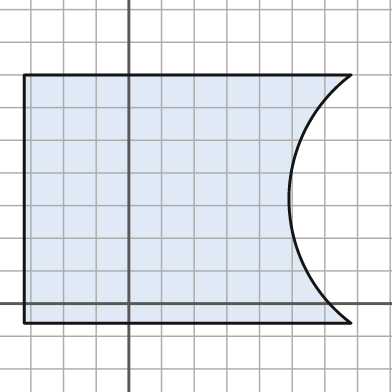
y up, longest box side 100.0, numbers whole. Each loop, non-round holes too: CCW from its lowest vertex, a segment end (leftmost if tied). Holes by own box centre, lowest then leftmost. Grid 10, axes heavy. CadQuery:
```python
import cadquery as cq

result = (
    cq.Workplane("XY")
    .moveTo(-32.0, -6.0)
    .lineTo(68.0, -6.0)
    .threePointArc((49.0, 32.0), (68.0, 70.0))
    .lineTo(-32.0, 70.0)
    .close()
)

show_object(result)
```